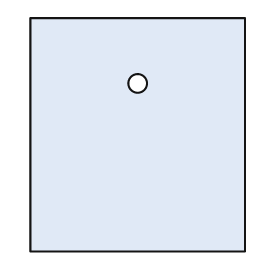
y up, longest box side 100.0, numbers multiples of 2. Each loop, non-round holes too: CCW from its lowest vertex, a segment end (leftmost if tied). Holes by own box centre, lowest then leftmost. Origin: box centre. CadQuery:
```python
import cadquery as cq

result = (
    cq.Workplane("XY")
    .moveTo(-46.0, -50.0)
    .lineTo(46.0, -50.0)
    .lineTo(46.0, 50.0)
    .lineTo(-46.0, 50.0)
    .close()
    .moveTo(0.0, 22.0)
    .circle(4.0)
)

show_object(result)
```